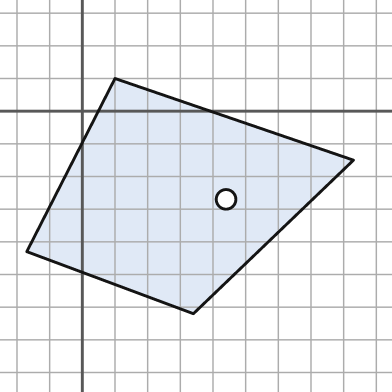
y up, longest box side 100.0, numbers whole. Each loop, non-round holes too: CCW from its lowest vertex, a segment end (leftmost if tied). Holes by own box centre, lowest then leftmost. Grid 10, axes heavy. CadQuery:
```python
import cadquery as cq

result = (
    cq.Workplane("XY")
    .moveTo(34.0, -62.0)
    .lineTo(83.0, -15.0)
    .lineTo(10.0, 10.0)
    .lineTo(-17.0, -43.0)
    .close()
    .moveTo(44.0, -27.0)
    .circle(3.0)
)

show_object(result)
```